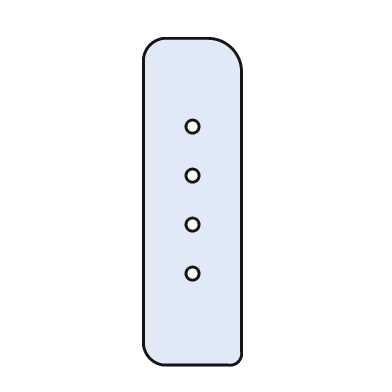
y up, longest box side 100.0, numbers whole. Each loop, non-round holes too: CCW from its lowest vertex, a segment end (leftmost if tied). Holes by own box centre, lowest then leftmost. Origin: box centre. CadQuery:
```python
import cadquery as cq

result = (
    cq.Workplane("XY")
    .moveTo(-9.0, -50.0)
    .lineTo(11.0, -50.0)
    .threePointArc((14.0, -49.0), (15.0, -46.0))
    .lineTo(15.0, 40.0)
    .threePointArc((12.0, 47.0), (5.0, 50.0))
    .lineTo(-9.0, 50.0)
    .threePointArc((-13.0, 48.0), (-15.0, 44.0))
    .lineTo(-15.0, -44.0)
    .threePointArc((-13.0, -48.0), (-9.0, -50.0))
    .close()
    .moveTo(0.0, -22.0)
    .circle(2.0)
    .moveTo(0.0, -7.0)
    .circle(2.0)
    .moveTo(0.0, 8.0)
    .circle(2.0)
    .moveTo(0.0, 23.0)
    .circle(2.0)
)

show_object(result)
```